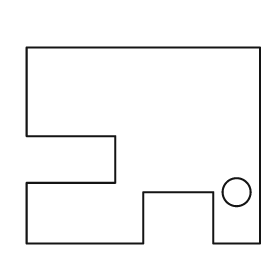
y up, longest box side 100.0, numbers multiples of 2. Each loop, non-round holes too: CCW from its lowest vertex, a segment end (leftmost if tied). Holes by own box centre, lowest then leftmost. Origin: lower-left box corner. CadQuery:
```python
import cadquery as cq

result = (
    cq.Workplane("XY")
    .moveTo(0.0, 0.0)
    .lineTo(50.0, 0.0)
    .lineTo(50.0, 22.0)
    .lineTo(80.0, 22.0)
    .lineTo(80.0, 0.0)
    .lineTo(100.0, 0.0)
    .lineTo(100.0, 84.0)
    .lineTo(0.0, 84.0)
    .lineTo(0.0, 46.0)
    .lineTo(38.0, 46.0)
    .lineTo(38.0, 26.0)
    .lineTo(0.0, 26.0)
    .close()
    .moveTo(90.0, 22.0)
    .circle(6.0)
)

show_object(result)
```